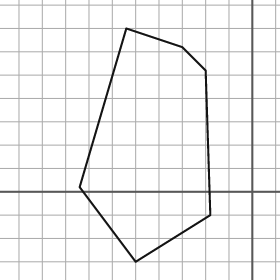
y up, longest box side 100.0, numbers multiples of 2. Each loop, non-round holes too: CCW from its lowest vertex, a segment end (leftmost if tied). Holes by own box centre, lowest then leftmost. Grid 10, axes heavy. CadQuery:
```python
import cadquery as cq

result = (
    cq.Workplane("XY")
    .moveTo(-50.0, -30.0)
    .lineTo(-18.0, -10.0)
    .lineTo(-20.0, 52.0)
    .lineTo(-30.0, 62.0)
    .lineTo(-54.0, 70.0)
    .lineTo(-74.0, 2.0)
    .close()
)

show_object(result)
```